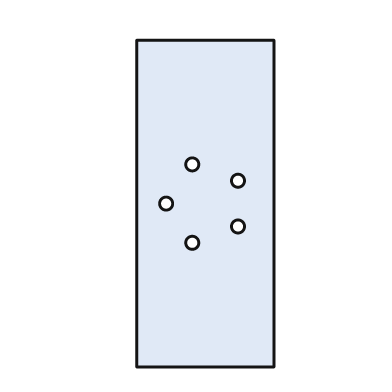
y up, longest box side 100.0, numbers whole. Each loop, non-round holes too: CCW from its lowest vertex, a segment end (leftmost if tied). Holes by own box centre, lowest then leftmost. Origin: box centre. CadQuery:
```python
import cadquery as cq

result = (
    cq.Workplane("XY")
    .moveTo(-21.0, -50.0)
    .lineTo(21.0, -50.0)
    .lineTo(21.0, 50.0)
    .lineTo(-21.0, 50.0)
    .close()
    .moveTo(-4.0, -12.0)
    .circle(2.0)
    .moveTo(10.0, -7.0)
    .circle(2.0)
    .moveTo(-12.0, 0.0)
    .circle(2.0)
    .moveTo(10.0, 7.0)
    .circle(2.0)
    .moveTo(-4.0, 12.0)
    .circle(2.0)
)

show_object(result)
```